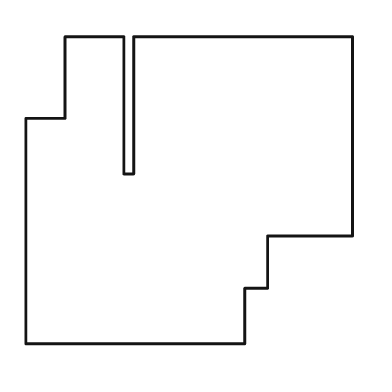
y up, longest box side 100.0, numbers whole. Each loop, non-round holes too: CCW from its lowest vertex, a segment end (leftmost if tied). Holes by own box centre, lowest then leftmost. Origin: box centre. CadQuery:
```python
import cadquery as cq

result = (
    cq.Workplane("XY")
    .moveTo(-50.0, -47.0)
    .lineTo(17.0, -47.0)
    .lineTo(17.0, -30.0)
    .lineTo(24.0, -30.0)
    .lineTo(24.0, -14.0)
    .lineTo(50.0, -14.0)
    .lineTo(50.0, 47.0)
    .lineTo(-17.0, 47.0)
    .lineTo(-17.0, 5.0)
    .lineTo(-20.0, 5.0)
    .lineTo(-20.0, 47.0)
    .lineTo(-38.0, 47.0)
    .lineTo(-38.0, 22.0)
    .lineTo(-50.0, 22.0)
    .close()
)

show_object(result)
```